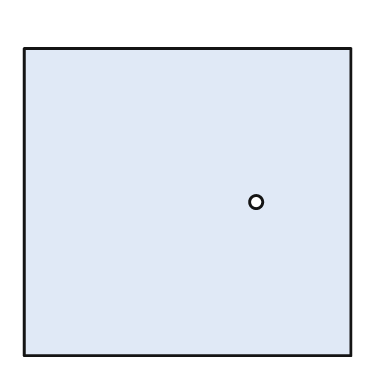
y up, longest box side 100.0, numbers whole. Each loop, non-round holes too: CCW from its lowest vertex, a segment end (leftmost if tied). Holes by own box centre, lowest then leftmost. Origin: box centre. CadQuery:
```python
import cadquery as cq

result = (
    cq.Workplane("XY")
    .moveTo(-50.0, -47.0)
    .lineTo(50.0, -47.0)
    .lineTo(50.0, 47.0)
    .lineTo(-50.0, 47.0)
    .close()
    .moveTo(21.0, 0.0)
    .circle(2.0)
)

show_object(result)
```